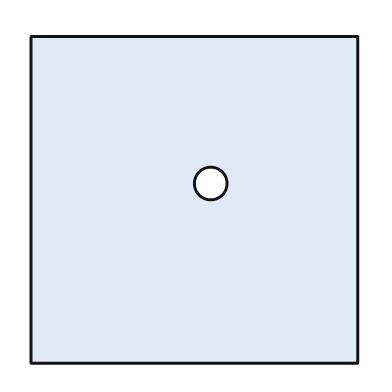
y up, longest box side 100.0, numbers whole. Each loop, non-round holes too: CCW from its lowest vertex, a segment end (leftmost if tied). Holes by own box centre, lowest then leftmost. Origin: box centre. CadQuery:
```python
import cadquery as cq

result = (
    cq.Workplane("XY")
    .moveTo(-50.0, -50.0)
    .lineTo(50.0, -50.0)
    .lineTo(50.0, 50.0)
    .lineTo(-50.0, 50.0)
    .close()
    .moveTo(5.0, 5.0)
    .circle(5.0)
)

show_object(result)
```